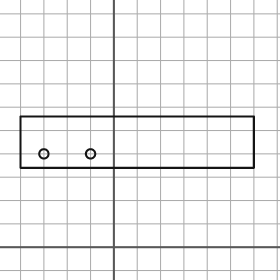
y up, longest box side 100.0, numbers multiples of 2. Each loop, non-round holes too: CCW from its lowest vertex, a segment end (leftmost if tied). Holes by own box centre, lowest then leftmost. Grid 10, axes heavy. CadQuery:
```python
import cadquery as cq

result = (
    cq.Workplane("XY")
    .moveTo(-40.0, 34.0)
    .lineTo(60.0, 34.0)
    .lineTo(60.0, 56.0)
    .lineTo(-40.0, 56.0)
    .close()
    .moveTo(-30.0, 40.0)
    .circle(2.0)
    .moveTo(-10.0, 40.0)
    .circle(2.0)
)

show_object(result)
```